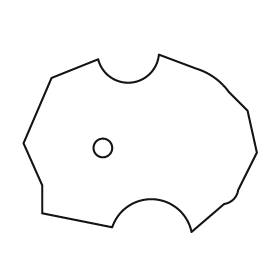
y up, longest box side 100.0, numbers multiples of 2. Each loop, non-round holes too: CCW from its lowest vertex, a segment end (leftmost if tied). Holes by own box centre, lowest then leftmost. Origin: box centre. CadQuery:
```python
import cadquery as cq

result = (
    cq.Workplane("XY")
    .moveTo(22.0, -38.0)
    .lineTo(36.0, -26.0)
    .threePointArc((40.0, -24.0), (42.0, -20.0))
    .lineTo(50.0, -4.0)
    .lineTo(46.0, 14.0)
    .lineTo(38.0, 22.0)
    .threePointArc((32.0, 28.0), (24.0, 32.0))
    .lineTo(8.0, 38.0)
    .threePointArc((-4.0, 26.0), (-18.0, 36.0))
    .lineTo(-38.0, 28.0)
    .lineTo(-50.0, 0.0)
    .lineTo(-42.0, -18.0)
    .lineTo(-42.0, -30.0)
    .lineTo(-12.0, -36.0)
    .threePointArc((6.0, -24.0), (22.0, -38.0))
    .close()
    .moveTo(-16.0, -2.0)
    .circle(4.0)
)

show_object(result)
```